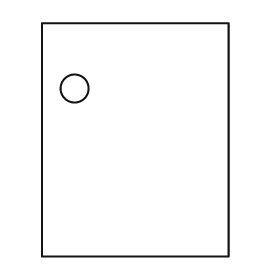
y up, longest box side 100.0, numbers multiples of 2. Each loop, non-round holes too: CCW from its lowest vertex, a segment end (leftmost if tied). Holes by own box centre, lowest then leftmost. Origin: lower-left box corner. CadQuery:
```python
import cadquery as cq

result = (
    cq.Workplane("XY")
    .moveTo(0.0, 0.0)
    .lineTo(80.0, 0.0)
    .lineTo(80.0, 100.0)
    .lineTo(0.0, 100.0)
    .close()
    .moveTo(14.0, 72.0)
    .circle(6.0)
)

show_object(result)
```